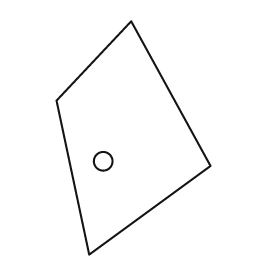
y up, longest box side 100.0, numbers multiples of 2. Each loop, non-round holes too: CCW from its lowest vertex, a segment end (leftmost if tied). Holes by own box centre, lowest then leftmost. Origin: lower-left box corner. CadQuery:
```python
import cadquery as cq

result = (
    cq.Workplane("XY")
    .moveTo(14.0, 0.0)
    .lineTo(66.0, 38.0)
    .lineTo(32.0, 100.0)
    .lineTo(0.0, 66.0)
    .close()
    .moveTo(20.0, 40.0)
    .circle(4.0)
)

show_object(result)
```